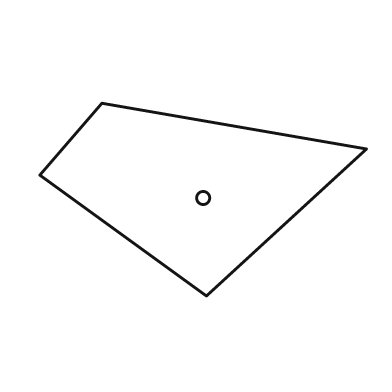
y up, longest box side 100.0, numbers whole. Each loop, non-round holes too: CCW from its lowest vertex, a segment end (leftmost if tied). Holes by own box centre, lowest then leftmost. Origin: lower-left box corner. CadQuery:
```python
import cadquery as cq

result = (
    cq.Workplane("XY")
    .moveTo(51.0, 0.0)
    .lineTo(100.0, 45.0)
    .lineTo(19.0, 59.0)
    .lineTo(0.0, 37.0)
    .close()
    .moveTo(50.0, 30.0)
    .circle(2.0)
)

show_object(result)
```